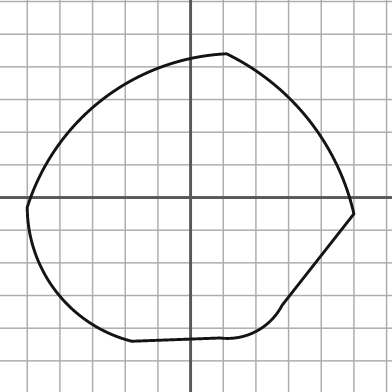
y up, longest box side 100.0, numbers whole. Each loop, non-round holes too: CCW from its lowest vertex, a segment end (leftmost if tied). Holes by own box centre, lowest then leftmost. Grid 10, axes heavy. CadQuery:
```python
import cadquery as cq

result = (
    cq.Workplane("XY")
    .moveTo(-18.0, -44.0)
    .lineTo(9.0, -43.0)
    .threePointArc((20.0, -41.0), (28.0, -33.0))
    .lineTo(50.0, -5.0)
    .threePointArc((36.0, 24.0), (11.0, 44.0))
    .threePointArc((-27.0, 30.0), (-50.0, -3.0))
    .threePointArc((-41.0, -29.0), (-18.0, -44.0))
    .close()
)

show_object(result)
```